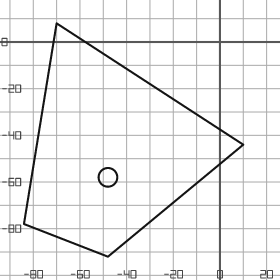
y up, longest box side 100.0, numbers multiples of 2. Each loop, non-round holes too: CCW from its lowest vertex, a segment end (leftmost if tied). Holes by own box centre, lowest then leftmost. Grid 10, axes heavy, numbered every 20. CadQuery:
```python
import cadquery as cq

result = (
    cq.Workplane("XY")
    .moveTo(-48.0, -92.0)
    .lineTo(10.0, -44.0)
    .lineTo(-70.0, 8.0)
    .lineTo(-84.0, -78.0)
    .close()
    .moveTo(-48.0, -58.0)
    .circle(4.0)
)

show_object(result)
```